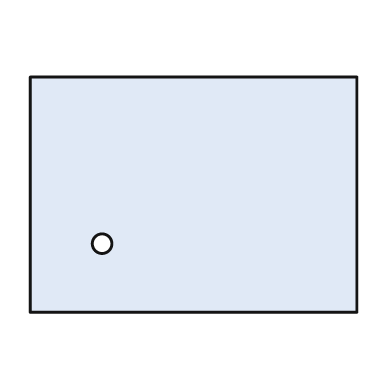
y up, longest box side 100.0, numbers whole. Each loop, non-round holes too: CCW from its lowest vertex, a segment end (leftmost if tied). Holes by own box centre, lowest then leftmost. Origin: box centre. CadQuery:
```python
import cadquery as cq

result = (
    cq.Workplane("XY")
    .moveTo(-50.0, -36.0)
    .lineTo(50.0, -36.0)
    .lineTo(50.0, 36.0)
    .lineTo(-50.0, 36.0)
    .close()
    .moveTo(-28.0, -15.0)
    .circle(3.0)
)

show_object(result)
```